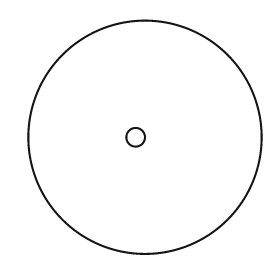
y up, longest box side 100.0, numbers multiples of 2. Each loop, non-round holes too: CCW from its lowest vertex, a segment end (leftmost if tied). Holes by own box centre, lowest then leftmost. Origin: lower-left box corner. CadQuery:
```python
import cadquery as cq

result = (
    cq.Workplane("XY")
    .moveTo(50.0, 50.0)
    .circle(50.0)
    .moveTo(46.0, 50.0)
    .circle(4.0)
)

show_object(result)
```